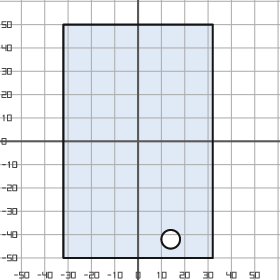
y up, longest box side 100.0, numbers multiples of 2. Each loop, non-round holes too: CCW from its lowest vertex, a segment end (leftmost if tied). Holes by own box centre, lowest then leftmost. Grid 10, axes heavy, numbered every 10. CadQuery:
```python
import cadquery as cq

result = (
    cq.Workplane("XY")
    .moveTo(-32.0, -50.0)
    .lineTo(32.0, -50.0)
    .lineTo(32.0, 50.0)
    .lineTo(-32.0, 50.0)
    .close()
    .moveTo(14.0, -42.0)
    .circle(4.0)
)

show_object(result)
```